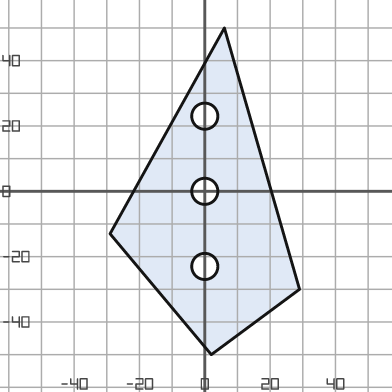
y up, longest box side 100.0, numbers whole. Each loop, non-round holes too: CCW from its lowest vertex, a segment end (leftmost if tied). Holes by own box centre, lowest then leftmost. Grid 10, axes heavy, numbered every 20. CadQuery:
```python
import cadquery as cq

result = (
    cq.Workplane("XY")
    .moveTo(2.0, -50.0)
    .lineTo(29.0, -30.0)
    .lineTo(6.0, 50.0)
    .lineTo(-29.0, -13.0)
    .close()
    .moveTo(0.0, -23.0)
    .circle(4.0)
    .moveTo(0.0, 0.0)
    .circle(4.0)
    .moveTo(0.0, 23.0)
    .circle(4.0)
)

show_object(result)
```